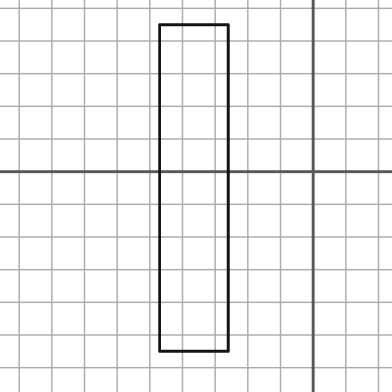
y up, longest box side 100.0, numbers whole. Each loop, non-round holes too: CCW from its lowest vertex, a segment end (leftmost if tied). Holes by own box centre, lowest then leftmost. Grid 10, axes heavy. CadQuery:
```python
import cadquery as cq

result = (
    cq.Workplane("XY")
    .moveTo(-47.0, -55.0)
    .lineTo(-26.0, -55.0)
    .lineTo(-26.0, 45.0)
    .lineTo(-47.0, 45.0)
    .close()
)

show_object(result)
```